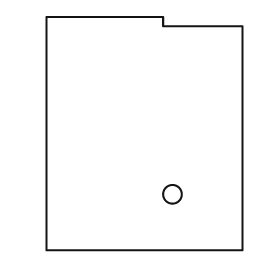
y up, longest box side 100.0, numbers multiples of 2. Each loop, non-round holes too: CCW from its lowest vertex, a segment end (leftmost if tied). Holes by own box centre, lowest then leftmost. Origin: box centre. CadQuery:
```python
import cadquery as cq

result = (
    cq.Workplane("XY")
    .moveTo(-42.0, -50.0)
    .lineTo(42.0, -50.0)
    .lineTo(42.0, 46.0)
    .lineTo(8.0, 46.0)
    .lineTo(8.0, 50.0)
    .lineTo(-42.0, 50.0)
    .close()
    .moveTo(12.0, -26.0)
    .circle(4.0)
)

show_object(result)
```